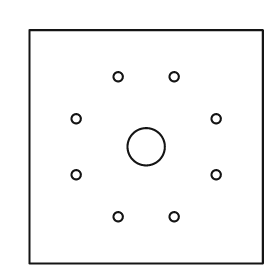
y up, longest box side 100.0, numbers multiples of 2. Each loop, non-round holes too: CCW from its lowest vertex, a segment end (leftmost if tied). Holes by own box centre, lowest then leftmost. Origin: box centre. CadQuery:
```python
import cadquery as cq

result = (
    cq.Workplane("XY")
    .moveTo(-50.0, -50.0)
    .lineTo(50.0, -50.0)
    .lineTo(50.0, 50.0)
    .lineTo(-50.0, 50.0)
    .close()
    .moveTo(-12.0, -30.0)
    .circle(2.0)
    .moveTo(12.0, -30.0)
    .circle(2.0)
    .moveTo(-30.0, -12.0)
    .circle(2.0)
    .moveTo(30.0, -12.0)
    .circle(2.0)
    .moveTo(0.0, 0.0)
    .circle(8.0)
    .moveTo(-30.0, 12.0)
    .circle(2.0)
    .moveTo(30.0, 12.0)
    .circle(2.0)
    .moveTo(-12.0, 30.0)
    .circle(2.0)
    .moveTo(12.0, 30.0)
    .circle(2.0)
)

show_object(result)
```